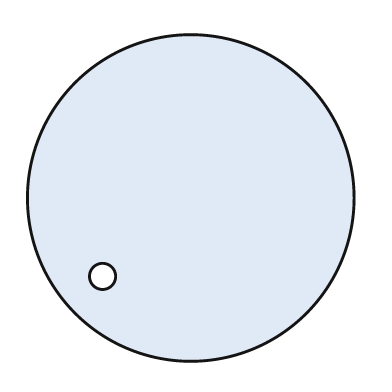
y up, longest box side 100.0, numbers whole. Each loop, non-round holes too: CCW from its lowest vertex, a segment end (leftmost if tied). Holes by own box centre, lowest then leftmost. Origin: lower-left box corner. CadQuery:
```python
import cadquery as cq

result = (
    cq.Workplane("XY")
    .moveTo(50.0, 50.0)
    .circle(50.0)
    .moveTo(23.0, 26.0)
    .circle(4.0)
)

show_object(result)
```